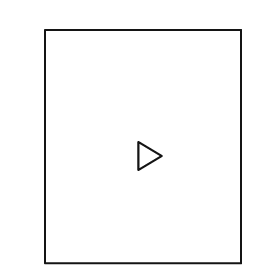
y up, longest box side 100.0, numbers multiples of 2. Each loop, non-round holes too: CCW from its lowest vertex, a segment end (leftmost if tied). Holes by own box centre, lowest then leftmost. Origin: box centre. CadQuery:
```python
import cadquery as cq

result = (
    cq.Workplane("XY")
    .moveTo(-42.0, -50.0)
    .lineTo(42.0, -50.0)
    .lineTo(42.0, 50.0)
    .lineTo(-42.0, 50.0)
    .close()
    .moveTo(-2.0, -10.0)
    .lineTo(8.0, -4.0)
    .lineTo(-2.0, 2.0)
    .close()
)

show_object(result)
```